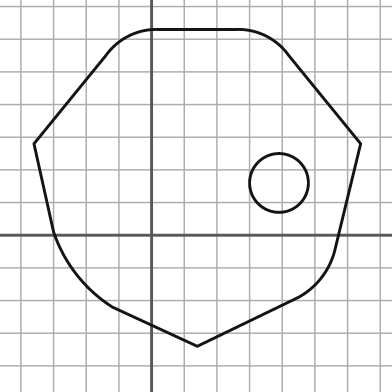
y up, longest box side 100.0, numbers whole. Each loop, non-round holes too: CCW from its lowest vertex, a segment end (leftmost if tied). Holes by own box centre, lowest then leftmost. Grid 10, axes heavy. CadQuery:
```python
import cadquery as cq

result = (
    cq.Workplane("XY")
    .moveTo(14.0, -34.0)
    .lineTo(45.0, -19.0)
    .threePointArc((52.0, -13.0), (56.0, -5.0))
    .lineTo(64.0, 28.0)
    .lineTo(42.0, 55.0)
    .threePointArc((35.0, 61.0), (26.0, 63.0))
    .lineTo(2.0, 63.0)
    .threePointArc((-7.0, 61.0), (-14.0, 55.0))
    .lineTo(-36.0, 28.0)
    .lineTo(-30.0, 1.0)
    .threePointArc((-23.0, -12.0), (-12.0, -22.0))
    .close()
    .moveTo(39.0, 16.0)
    .circle(9.0)
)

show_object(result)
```